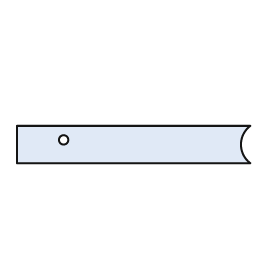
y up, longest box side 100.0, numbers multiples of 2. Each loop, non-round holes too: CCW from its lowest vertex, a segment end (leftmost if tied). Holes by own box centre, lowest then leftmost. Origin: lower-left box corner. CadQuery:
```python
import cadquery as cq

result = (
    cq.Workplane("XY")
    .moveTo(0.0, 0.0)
    .lineTo(100.0, 0.0)
    .threePointArc((96.0, 8.0), (100.0, 16.0))
    .lineTo(0.0, 16.0)
    .close()
    .moveTo(20.0, 10.0)
    .circle(2.0)
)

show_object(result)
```